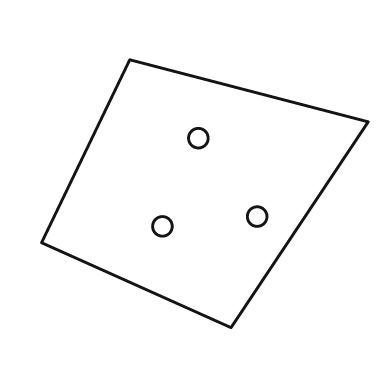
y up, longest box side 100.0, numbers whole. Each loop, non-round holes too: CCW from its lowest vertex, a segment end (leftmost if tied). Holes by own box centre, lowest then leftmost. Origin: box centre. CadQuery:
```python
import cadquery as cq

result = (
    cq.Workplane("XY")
    .moveTo(8.0, -41.0)
    .lineTo(50.0, 22.0)
    .lineTo(-23.0, 41.0)
    .lineTo(-50.0, -15.0)
    .close()
    .moveTo(-13.0, -10.0)
    .circle(3.0)
    .moveTo(16.0, -7.0)
    .circle(3.0)
    .moveTo(-2.0, 17.0)
    .circle(3.0)
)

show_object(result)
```